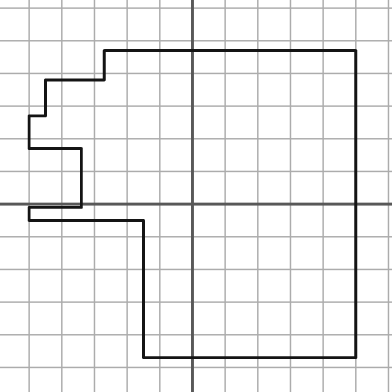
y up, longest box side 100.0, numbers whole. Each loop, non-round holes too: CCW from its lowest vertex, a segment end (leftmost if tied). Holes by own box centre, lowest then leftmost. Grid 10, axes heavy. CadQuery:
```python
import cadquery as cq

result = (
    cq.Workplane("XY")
    .moveTo(-15.0, -47.0)
    .lineTo(50.0, -47.0)
    .lineTo(50.0, 47.0)
    .lineTo(-27.0, 47.0)
    .lineTo(-27.0, 38.0)
    .lineTo(-45.0, 38.0)
    .lineTo(-45.0, 27.0)
    .lineTo(-50.0, 27.0)
    .lineTo(-50.0, 17.0)
    .lineTo(-34.0, 17.0)
    .lineTo(-34.0, -1.0)
    .lineTo(-50.0, -1.0)
    .lineTo(-50.0, -5.0)
    .lineTo(-15.0, -5.0)
    .close()
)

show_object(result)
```